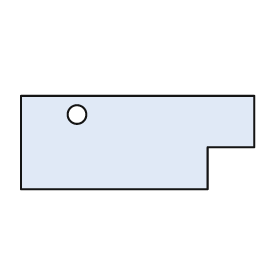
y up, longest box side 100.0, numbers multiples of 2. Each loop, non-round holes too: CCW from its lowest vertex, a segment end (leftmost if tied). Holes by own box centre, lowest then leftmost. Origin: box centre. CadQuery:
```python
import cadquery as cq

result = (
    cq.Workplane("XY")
    .moveTo(-50.0, -20.0)
    .lineTo(30.0, -20.0)
    .lineTo(30.0, -2.0)
    .lineTo(50.0, -2.0)
    .lineTo(50.0, 20.0)
    .lineTo(-50.0, 20.0)
    .close()
    .moveTo(-26.0, 12.0)
    .circle(4.0)
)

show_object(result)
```